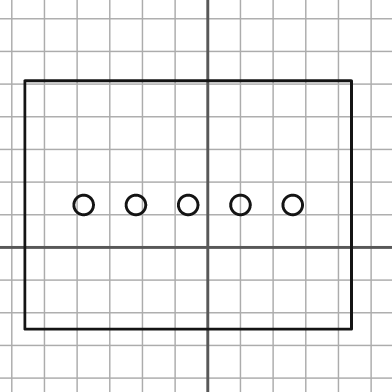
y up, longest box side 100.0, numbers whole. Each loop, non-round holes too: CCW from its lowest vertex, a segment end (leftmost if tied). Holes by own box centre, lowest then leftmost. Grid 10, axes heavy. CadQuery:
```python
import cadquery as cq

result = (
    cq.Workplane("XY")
    .moveTo(-56.0, -25.0)
    .lineTo(44.0, -25.0)
    .lineTo(44.0, 51.0)
    .lineTo(-56.0, 51.0)
    .close()
    .moveTo(-38.0, 13.0)
    .circle(3.0)
    .moveTo(-22.0, 13.0)
    .circle(3.0)
    .moveTo(-6.0, 13.0)
    .circle(3.0)
    .moveTo(10.0, 13.0)
    .circle(3.0)
    .moveTo(26.0, 13.0)
    .circle(3.0)
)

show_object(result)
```